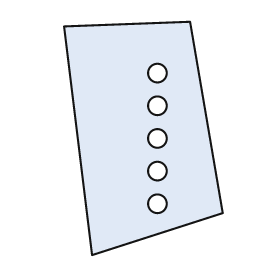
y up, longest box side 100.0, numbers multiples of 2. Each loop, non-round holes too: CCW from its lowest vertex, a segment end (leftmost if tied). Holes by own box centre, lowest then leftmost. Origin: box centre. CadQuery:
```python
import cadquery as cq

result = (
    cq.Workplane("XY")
    .moveTo(-22.0, -50.0)
    .lineTo(34.0, -32.0)
    .lineTo(20.0, 50.0)
    .lineTo(-34.0, 48.0)
    .close()
    .moveTo(6.0, -28.0)
    .circle(4.0)
    .moveTo(6.0, -14.0)
    .circle(4.0)
    .moveTo(6.0, 0.0)
    .circle(4.0)
    .moveTo(6.0, 14.0)
    .circle(4.0)
    .moveTo(6.0, 28.0)
    .circle(4.0)
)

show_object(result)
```